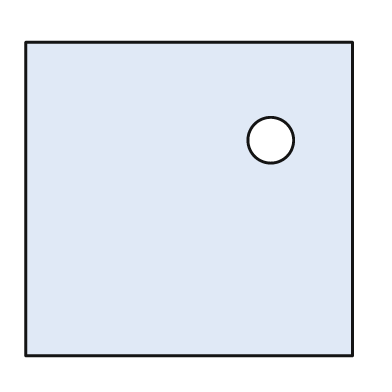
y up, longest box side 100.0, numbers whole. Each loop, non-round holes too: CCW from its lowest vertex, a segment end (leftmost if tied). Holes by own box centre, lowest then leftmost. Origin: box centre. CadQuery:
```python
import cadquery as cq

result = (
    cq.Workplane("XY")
    .moveTo(-50.0, -48.0)
    .lineTo(50.0, -48.0)
    .lineTo(50.0, 48.0)
    .lineTo(-50.0, 48.0)
    .close()
    .moveTo(25.0, 18.0)
    .circle(7.0)
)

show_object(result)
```